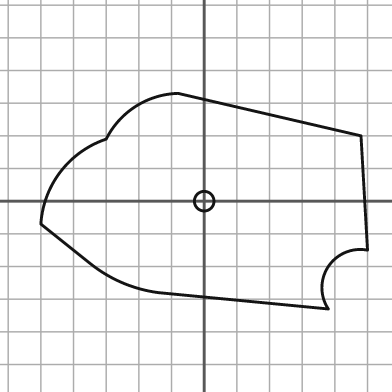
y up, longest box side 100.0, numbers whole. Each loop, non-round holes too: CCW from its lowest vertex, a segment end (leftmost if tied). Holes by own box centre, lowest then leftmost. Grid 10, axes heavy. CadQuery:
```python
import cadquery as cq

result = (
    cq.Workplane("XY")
    .moveTo(38.0, -33.0)
    .threePointArc((38.0, -20.0), (50.0, -15.0))
    .lineTo(48.0, 20.0)
    .lineTo(-8.0, 33.0)
    .threePointArc((-21.0, 29.0), (-30.0, 19.0))
    .threePointArc((-44.0, 9.0), (-50.0, -7.0))
    .lineTo(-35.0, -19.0)
    .threePointArc((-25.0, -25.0), (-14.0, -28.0))
    .close()
    .moveTo(0.0, 0.0)
    .circle(3.0)
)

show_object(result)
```